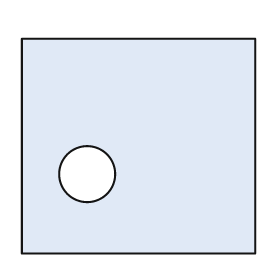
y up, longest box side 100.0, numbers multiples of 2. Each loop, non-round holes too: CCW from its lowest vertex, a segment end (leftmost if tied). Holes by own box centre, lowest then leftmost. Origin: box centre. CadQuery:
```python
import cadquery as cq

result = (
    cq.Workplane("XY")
    .moveTo(-50.0, -46.0)
    .lineTo(50.0, -46.0)
    .lineTo(50.0, 46.0)
    .lineTo(-50.0, 46.0)
    .close()
    .moveTo(-22.0, -12.0)
    .circle(12.0)
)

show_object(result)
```